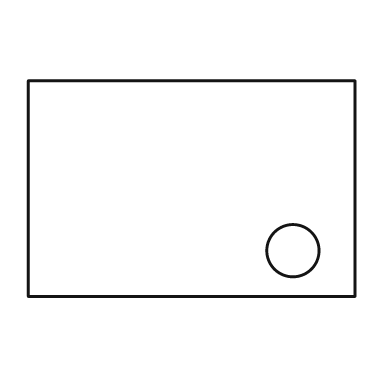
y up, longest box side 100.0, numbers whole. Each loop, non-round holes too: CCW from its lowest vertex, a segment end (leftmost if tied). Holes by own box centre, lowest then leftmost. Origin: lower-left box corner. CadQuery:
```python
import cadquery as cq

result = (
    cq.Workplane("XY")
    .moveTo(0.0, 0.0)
    .lineTo(100.0, 0.0)
    .lineTo(100.0, 66.0)
    .lineTo(0.0, 66.0)
    .close()
    .moveTo(81.0, 14.0)
    .circle(8.0)
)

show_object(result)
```